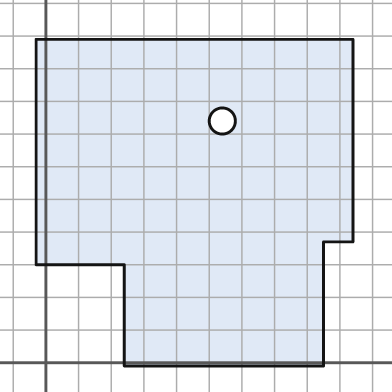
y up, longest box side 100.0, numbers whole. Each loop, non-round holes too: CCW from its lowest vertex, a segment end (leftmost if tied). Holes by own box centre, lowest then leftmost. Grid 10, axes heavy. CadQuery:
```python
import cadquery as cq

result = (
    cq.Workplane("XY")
    .moveTo(24.0, -1.0)
    .lineTo(85.0, -1.0)
    .lineTo(85.0, 37.0)
    .lineTo(94.0, 37.0)
    .lineTo(94.0, 99.0)
    .lineTo(-3.0, 99.0)
    .lineTo(-3.0, 30.0)
    .lineTo(24.0, 30.0)
    .close()
    .moveTo(54.0, 74.0)
    .circle(4.0)
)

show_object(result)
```